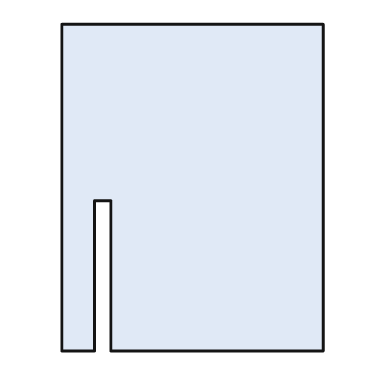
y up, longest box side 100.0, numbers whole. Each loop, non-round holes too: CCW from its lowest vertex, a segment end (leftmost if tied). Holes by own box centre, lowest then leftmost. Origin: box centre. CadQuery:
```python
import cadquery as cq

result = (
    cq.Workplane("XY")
    .moveTo(-40.0, -50.0)
    .lineTo(-30.0, -50.0)
    .lineTo(-30.0, -4.0)
    .lineTo(-25.0, -4.0)
    .lineTo(-25.0, -50.0)
    .lineTo(40.0, -50.0)
    .lineTo(40.0, 50.0)
    .lineTo(-40.0, 50.0)
    .close()
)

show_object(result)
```